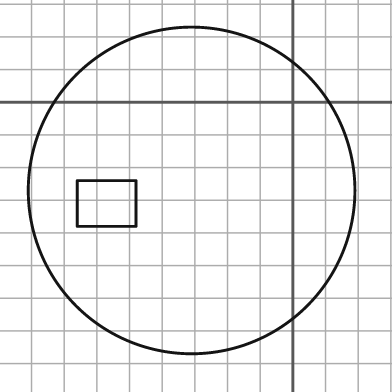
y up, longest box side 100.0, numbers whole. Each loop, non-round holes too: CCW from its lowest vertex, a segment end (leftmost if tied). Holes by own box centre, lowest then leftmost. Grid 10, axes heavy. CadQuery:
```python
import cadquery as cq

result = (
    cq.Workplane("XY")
    .moveTo(-31.0, -27.0)
    .circle(50.0)
    .moveTo(-66.0, -38.0)
    .lineTo(-48.0, -38.0)
    .lineTo(-48.0, -24.0)
    .lineTo(-66.0, -24.0)
    .close()
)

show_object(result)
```